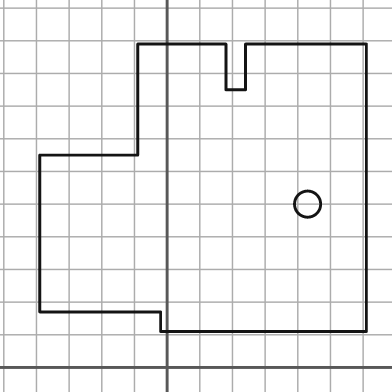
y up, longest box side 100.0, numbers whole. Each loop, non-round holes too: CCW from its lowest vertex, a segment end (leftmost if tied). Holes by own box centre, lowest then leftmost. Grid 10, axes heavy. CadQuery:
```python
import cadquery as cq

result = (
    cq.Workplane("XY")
    .moveTo(-2.0, 11.0)
    .lineTo(61.0, 11.0)
    .lineTo(61.0, 99.0)
    .lineTo(24.0, 99.0)
    .lineTo(24.0, 85.0)
    .lineTo(18.0, 85.0)
    .lineTo(18.0, 99.0)
    .lineTo(-9.0, 99.0)
    .lineTo(-9.0, 65.0)
    .lineTo(-39.0, 65.0)
    .lineTo(-39.0, 17.0)
    .lineTo(-2.0, 17.0)
    .close()
    .moveTo(43.0, 50.0)
    .circle(4.0)
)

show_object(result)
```